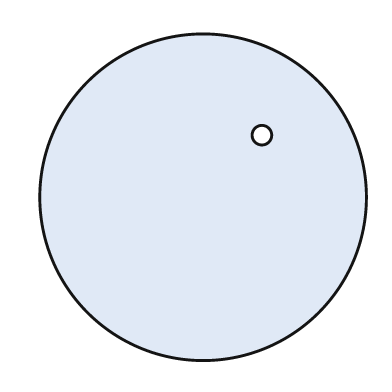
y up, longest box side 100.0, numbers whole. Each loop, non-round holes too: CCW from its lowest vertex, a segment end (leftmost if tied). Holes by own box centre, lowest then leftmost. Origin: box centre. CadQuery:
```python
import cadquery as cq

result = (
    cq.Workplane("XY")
    .moveTo(0.0, 0.0)
    .circle(50.0)
    .moveTo(18.0, 19.0)
    .circle(3.0)
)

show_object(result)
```